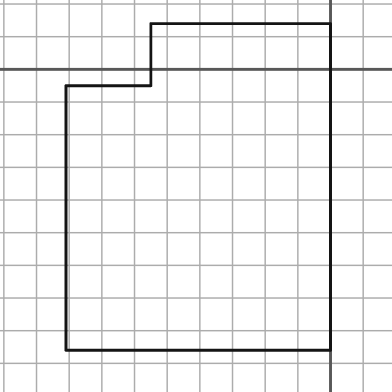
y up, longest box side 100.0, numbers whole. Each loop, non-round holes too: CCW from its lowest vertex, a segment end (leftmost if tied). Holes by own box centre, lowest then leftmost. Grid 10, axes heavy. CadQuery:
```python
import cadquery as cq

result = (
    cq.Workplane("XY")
    .moveTo(-81.0, -86.0)
    .lineTo(0.0, -86.0)
    .lineTo(0.0, 14.0)
    .lineTo(-55.0, 14.0)
    .lineTo(-55.0, -5.0)
    .lineTo(-81.0, -5.0)
    .close()
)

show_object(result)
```